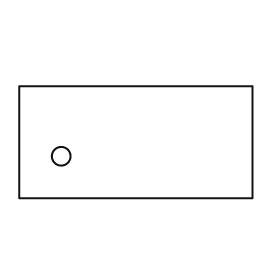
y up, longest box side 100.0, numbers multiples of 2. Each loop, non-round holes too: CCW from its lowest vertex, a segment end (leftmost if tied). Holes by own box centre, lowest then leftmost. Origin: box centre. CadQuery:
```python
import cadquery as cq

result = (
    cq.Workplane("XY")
    .moveTo(-50.0, -24.0)
    .lineTo(50.0, -24.0)
    .lineTo(50.0, 24.0)
    .lineTo(-50.0, 24.0)
    .close()
    .moveTo(-32.0, -6.0)
    .circle(4.0)
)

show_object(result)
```